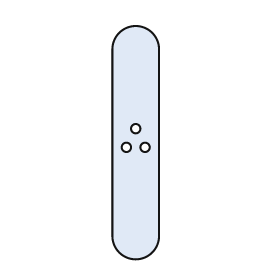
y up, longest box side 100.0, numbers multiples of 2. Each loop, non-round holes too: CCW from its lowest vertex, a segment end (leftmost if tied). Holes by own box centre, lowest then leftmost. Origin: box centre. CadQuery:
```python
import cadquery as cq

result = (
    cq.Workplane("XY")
    .moveTo(-10.0, -40.0)
    .threePointArc((0.0, -50.0), (10.0, -40.0))
    .lineTo(10.0, 40.0)
    .threePointArc((0.0, 50.0), (-10.0, 40.0))
    .close()
    .moveTo(-4.0, -2.0)
    .circle(2.0)
    .moveTo(4.0, -2.0)
    .circle(2.0)
    .moveTo(0.0, 6.0)
    .circle(2.0)
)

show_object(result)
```